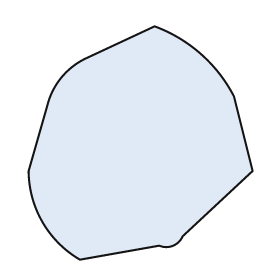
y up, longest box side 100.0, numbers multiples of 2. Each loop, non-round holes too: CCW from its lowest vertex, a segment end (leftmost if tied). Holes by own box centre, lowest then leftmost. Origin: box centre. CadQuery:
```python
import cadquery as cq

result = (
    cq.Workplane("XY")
    .moveTo(-26.0, -50.0)
    .lineTo(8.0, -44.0)
    .threePointArc((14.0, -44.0), (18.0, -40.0))
    .lineTo(48.0, -12.0)
    .lineTo(40.0, 20.0)
    .threePointArc((26.0, 38.0), (6.0, 50.0))
    .lineTo(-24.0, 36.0)
    .threePointArc((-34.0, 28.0), (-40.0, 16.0))
    .lineTo(-48.0, -12.0)
    .threePointArc((-42.0, -34.0), (-26.0, -50.0))
    .close()
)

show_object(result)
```